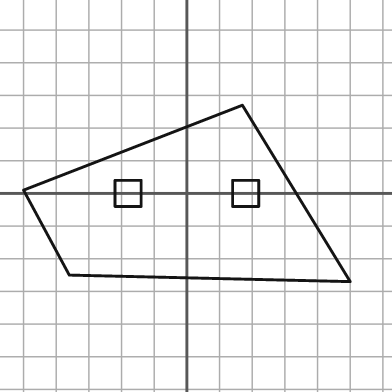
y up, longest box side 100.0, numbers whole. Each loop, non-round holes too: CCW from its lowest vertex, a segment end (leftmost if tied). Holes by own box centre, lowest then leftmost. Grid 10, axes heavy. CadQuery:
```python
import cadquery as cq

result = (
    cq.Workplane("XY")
    .moveTo(50.0, -27.0)
    .lineTo(17.0, 27.0)
    .lineTo(-50.0, 1.0)
    .lineTo(-36.0, -25.0)
    .close()
    .moveTo(-22.0, -4.0)
    .lineTo(-14.0, -4.0)
    .lineTo(-14.0, 4.0)
    .lineTo(-22.0, 4.0)
    .close()
    .moveTo(14.0, -4.0)
    .lineTo(22.0, -4.0)
    .lineTo(22.0, 4.0)
    .lineTo(14.0, 4.0)
    .close()
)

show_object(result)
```